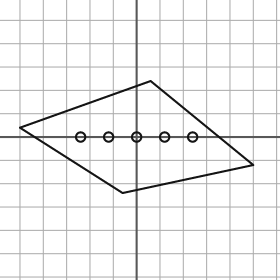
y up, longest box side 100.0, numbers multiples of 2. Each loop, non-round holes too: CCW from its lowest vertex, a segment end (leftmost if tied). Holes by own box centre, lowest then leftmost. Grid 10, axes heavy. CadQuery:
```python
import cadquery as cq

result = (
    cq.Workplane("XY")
    .moveTo(-6.0, -24.0)
    .lineTo(50.0, -12.0)
    .lineTo(6.0, 24.0)
    .lineTo(-50.0, 4.0)
    .close()
    .moveTo(-24.0, 0.0)
    .circle(2.0)
    .moveTo(-12.0, 0.0)
    .circle(2.0)
    .moveTo(0.0, 0.0)
    .circle(2.0)
    .moveTo(12.0, 0.0)
    .circle(2.0)
    .moveTo(24.0, 0.0)
    .circle(2.0)
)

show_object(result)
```